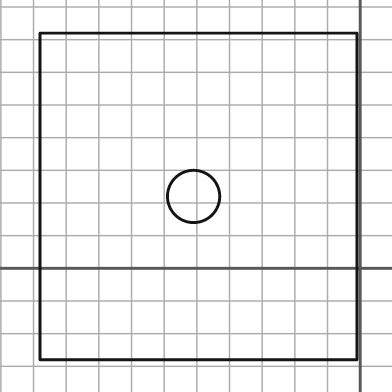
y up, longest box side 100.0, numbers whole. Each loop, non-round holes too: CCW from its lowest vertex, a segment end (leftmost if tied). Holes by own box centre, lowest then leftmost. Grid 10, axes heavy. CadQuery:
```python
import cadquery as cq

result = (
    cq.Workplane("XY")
    .moveTo(-98.0, -28.0)
    .lineTo(-1.0, -28.0)
    .lineTo(-1.0, 72.0)
    .lineTo(-98.0, 72.0)
    .close()
    .moveTo(-51.0, 22.0)
    .circle(8.0)
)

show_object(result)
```